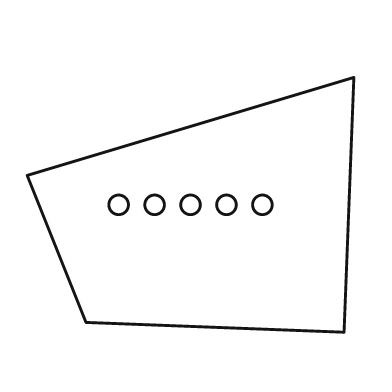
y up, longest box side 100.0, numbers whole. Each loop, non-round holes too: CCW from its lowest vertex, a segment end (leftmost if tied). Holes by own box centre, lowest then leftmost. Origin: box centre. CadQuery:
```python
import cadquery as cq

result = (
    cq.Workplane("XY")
    .moveTo(47.0, -39.0)
    .lineTo(50.0, 39.0)
    .lineTo(-50.0, 9.0)
    .lineTo(-32.0, -36.0)
    .close()
    .moveTo(-22.0, 0.0)
    .circle(3.0)
    .moveTo(-11.0, 0.0)
    .circle(3.0)
    .moveTo(0.0, 0.0)
    .circle(3.0)
    .moveTo(11.0, 0.0)
    .circle(3.0)
    .moveTo(22.0, 0.0)
    .circle(3.0)
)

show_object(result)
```